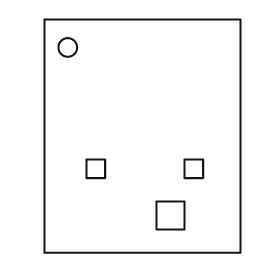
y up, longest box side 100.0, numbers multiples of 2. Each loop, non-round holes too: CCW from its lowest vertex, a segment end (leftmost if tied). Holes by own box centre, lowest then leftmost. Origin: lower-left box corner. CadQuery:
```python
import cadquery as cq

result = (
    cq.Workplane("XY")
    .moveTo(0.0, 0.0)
    .lineTo(84.0, 0.0)
    .lineTo(84.0, 100.0)
    .lineTo(0.0, 100.0)
    .close()
    .moveTo(48.0, 10.0)
    .lineTo(60.0, 10.0)
    .lineTo(60.0, 22.0)
    .lineTo(48.0, 22.0)
    .close()
    .moveTo(18.0, 32.0)
    .lineTo(26.0, 32.0)
    .lineTo(26.0, 40.0)
    .lineTo(18.0, 40.0)
    .close()
    .moveTo(60.0, 32.0)
    .lineTo(68.0, 32.0)
    .lineTo(68.0, 40.0)
    .lineTo(60.0, 40.0)
    .close()
    .moveTo(10.0, 88.0)
    .circle(4.0)
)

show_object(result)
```